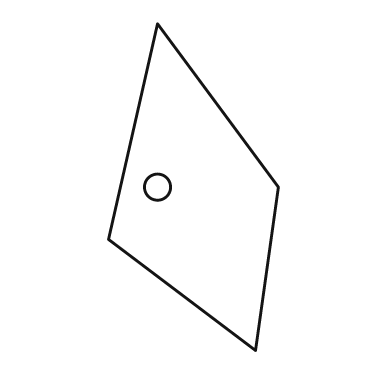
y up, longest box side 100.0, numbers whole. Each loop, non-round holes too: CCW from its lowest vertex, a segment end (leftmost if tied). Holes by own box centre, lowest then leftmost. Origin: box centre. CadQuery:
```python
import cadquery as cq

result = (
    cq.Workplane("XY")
    .moveTo(19.0, -50.0)
    .lineTo(26.0, 0.0)
    .lineTo(-11.0, 50.0)
    .lineTo(-26.0, -16.0)
    .close()
    .moveTo(-11.0, 0.0)
    .circle(4.0)
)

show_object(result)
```